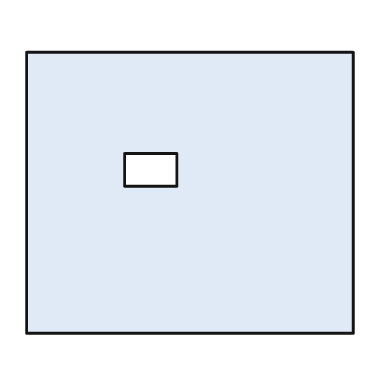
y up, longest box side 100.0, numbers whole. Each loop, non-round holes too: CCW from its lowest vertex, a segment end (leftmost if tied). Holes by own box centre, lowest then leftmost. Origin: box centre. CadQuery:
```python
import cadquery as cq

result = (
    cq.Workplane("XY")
    .moveTo(-50.0, -43.0)
    .lineTo(50.0, -43.0)
    .lineTo(50.0, 43.0)
    .lineTo(-50.0, 43.0)
    .close()
    .moveTo(-20.0, 2.0)
    .lineTo(-4.0, 2.0)
    .lineTo(-4.0, 12.0)
    .lineTo(-20.0, 12.0)
    .close()
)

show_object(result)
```